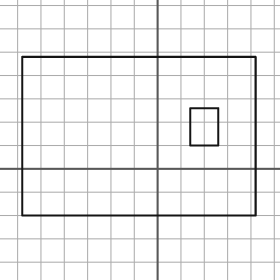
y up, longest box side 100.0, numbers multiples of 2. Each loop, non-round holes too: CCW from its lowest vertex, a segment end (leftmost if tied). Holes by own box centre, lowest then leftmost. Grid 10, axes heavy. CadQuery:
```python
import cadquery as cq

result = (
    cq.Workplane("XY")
    .moveTo(-58.0, -20.0)
    .lineTo(42.0, -20.0)
    .lineTo(42.0, 48.0)
    .lineTo(-58.0, 48.0)
    .close()
    .moveTo(14.0, 10.0)
    .lineTo(26.0, 10.0)
    .lineTo(26.0, 26.0)
    .lineTo(14.0, 26.0)
    .close()
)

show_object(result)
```